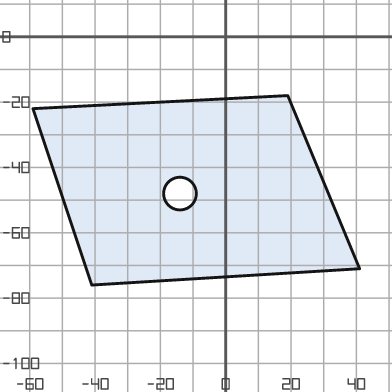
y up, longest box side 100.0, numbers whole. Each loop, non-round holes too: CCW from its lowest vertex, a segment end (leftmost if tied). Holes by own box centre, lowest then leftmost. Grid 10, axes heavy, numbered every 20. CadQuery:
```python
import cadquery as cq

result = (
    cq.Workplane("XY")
    .moveTo(-41.0, -76.0)
    .lineTo(41.0, -71.0)
    .lineTo(19.0, -18.0)
    .lineTo(-59.0, -22.0)
    .close()
    .moveTo(-14.0, -48.0)
    .circle(5.0)
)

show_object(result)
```